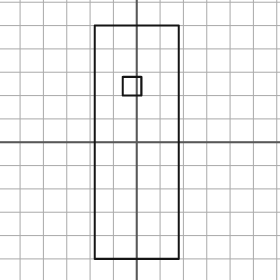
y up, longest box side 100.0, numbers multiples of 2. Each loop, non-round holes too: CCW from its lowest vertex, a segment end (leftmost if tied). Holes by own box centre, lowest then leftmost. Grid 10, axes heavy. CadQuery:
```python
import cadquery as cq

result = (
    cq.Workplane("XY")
    .moveTo(-18.0, -50.0)
    .lineTo(18.0, -50.0)
    .lineTo(18.0, 50.0)
    .lineTo(-18.0, 50.0)
    .close()
    .moveTo(-6.0, 20.0)
    .lineTo(2.0, 20.0)
    .lineTo(2.0, 28.0)
    .lineTo(-6.0, 28.0)
    .close()
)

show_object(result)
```